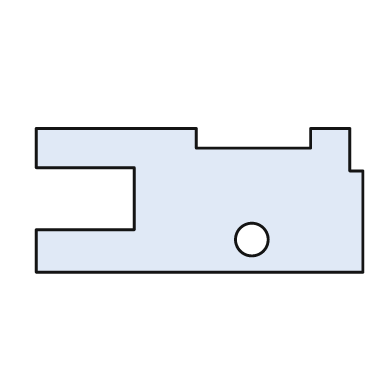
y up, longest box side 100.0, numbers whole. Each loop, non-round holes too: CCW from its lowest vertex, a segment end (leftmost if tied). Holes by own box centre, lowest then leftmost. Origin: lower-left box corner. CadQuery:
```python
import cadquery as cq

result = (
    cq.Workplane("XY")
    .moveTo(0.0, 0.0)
    .lineTo(100.0, 0.0)
    .lineTo(100.0, 31.0)
    .lineTo(96.0, 31.0)
    .lineTo(96.0, 44.0)
    .lineTo(84.0, 44.0)
    .lineTo(84.0, 38.0)
    .lineTo(49.0, 38.0)
    .lineTo(49.0, 44.0)
    .lineTo(0.0, 44.0)
    .lineTo(0.0, 32.0)
    .lineTo(30.0, 32.0)
    .lineTo(30.0, 13.0)
    .lineTo(0.0, 13.0)
    .close()
    .moveTo(66.0, 10.0)
    .circle(5.0)
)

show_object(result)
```